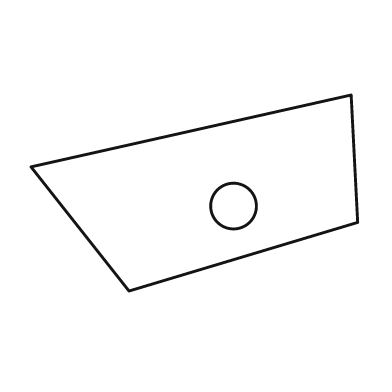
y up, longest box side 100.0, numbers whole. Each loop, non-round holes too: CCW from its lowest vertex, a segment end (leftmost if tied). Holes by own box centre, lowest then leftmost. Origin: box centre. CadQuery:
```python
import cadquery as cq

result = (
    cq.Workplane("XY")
    .moveTo(-20.0, -30.0)
    .lineTo(50.0, -9.0)
    .lineTo(48.0, 30.0)
    .lineTo(-50.0, 8.0)
    .close()
    .moveTo(12.0, -4.0)
    .circle(7.0)
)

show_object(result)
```